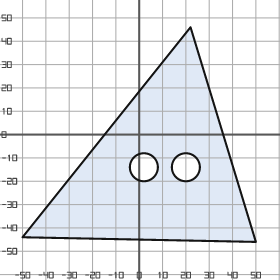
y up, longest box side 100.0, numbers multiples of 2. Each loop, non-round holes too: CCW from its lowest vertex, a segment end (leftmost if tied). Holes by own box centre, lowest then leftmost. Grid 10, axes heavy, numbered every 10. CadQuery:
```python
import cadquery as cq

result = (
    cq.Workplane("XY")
    .moveTo(50.0, -46.0)
    .lineTo(22.0, 46.0)
    .lineTo(-50.0, -44.0)
    .close()
    .moveTo(2.0, -14.0)
    .circle(6.0)
    .moveTo(20.0, -14.0)
    .circle(6.0)
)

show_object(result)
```